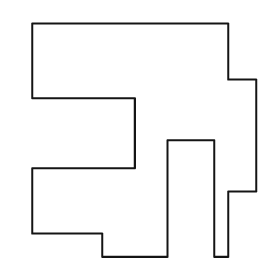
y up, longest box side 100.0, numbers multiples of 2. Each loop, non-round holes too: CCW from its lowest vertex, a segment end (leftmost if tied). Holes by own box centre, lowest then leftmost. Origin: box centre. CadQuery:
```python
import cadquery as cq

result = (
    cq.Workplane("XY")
    .moveTo(-18.0, -50.0)
    .lineTo(10.0, -50.0)
    .lineTo(10.0, 0.0)
    .lineTo(30.0, 0.0)
    .lineTo(30.0, -50.0)
    .lineTo(36.0, -50.0)
    .lineTo(36.0, -22.0)
    .lineTo(48.0, -22.0)
    .lineTo(48.0, 26.0)
    .lineTo(36.0, 26.0)
    .lineTo(36.0, 50.0)
    .lineTo(-48.0, 50.0)
    .lineTo(-48.0, 18.0)
    .lineTo(-4.0, 18.0)
    .lineTo(-4.0, -12.0)
    .lineTo(-48.0, -12.0)
    .lineTo(-48.0, -40.0)
    .lineTo(-18.0, -40.0)
    .close()
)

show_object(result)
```